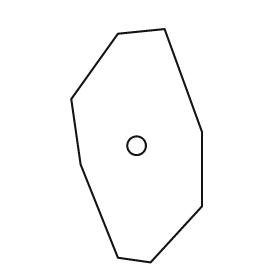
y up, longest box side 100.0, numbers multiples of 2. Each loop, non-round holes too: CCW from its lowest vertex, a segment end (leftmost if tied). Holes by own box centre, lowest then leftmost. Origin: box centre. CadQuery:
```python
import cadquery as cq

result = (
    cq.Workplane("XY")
    .moveTo(6.0, -50.0)
    .lineTo(28.0, -26.0)
    .lineTo(28.0, 6.0)
    .lineTo(12.0, 50.0)
    .lineTo(-8.0, 48.0)
    .lineTo(-28.0, 20.0)
    .lineTo(-24.0, -8.0)
    .lineTo(-8.0, -48.0)
    .close()
    .moveTo(0.0, 0.0)
    .circle(4.0)
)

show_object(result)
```